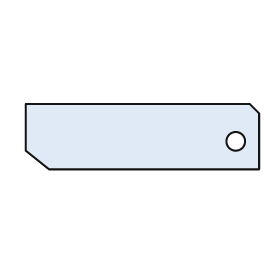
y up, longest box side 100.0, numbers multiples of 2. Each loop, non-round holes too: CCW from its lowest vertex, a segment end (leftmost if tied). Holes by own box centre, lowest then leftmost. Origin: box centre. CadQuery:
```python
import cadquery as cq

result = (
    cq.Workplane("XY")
    .moveTo(-40.0, -14.0)
    .lineTo(50.0, -14.0)
    .lineTo(50.0, 10.0)
    .lineTo(46.0, 14.0)
    .lineTo(-50.0, 14.0)
    .lineTo(-50.0, -6.0)
    .close()
    .moveTo(40.0, -2.0)
    .circle(4.0)
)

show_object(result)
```